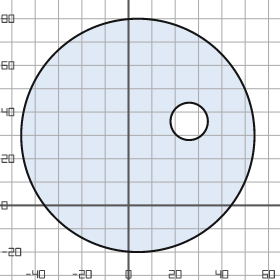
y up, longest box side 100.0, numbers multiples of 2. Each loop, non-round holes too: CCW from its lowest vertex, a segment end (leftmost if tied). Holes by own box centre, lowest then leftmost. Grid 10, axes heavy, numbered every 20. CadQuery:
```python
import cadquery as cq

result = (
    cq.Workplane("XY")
    .moveTo(4.0, 30.0)
    .circle(50.0)
    .moveTo(26.0, 36.0)
    .circle(8.0)
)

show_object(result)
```